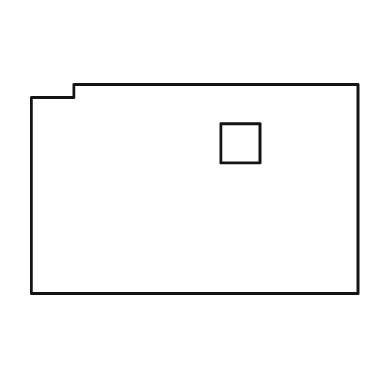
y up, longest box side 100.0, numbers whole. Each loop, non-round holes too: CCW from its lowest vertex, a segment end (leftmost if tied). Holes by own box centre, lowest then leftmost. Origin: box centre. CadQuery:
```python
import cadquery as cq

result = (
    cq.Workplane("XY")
    .moveTo(-50.0, -32.0)
    .lineTo(50.0, -32.0)
    .lineTo(50.0, 32.0)
    .lineTo(-37.0, 32.0)
    .lineTo(-37.0, 28.0)
    .lineTo(-50.0, 28.0)
    .close()
    .moveTo(8.0, 8.0)
    .lineTo(20.0, 8.0)
    .lineTo(20.0, 20.0)
    .lineTo(8.0, 20.0)
    .close()
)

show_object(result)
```